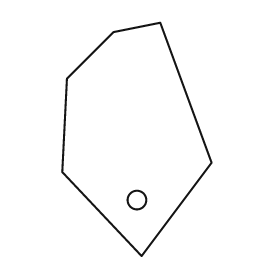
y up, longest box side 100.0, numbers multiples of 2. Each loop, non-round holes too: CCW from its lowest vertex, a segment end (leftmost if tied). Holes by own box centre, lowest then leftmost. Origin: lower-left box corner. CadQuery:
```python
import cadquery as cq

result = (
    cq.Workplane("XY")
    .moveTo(34.0, 0.0)
    .lineTo(64.0, 40.0)
    .lineTo(42.0, 100.0)
    .lineTo(22.0, 96.0)
    .lineTo(2.0, 76.0)
    .lineTo(0.0, 36.0)
    .close()
    .moveTo(32.0, 24.0)
    .circle(4.0)
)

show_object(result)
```